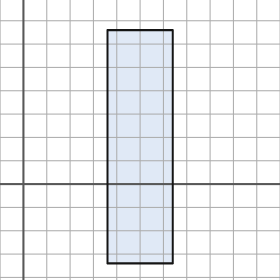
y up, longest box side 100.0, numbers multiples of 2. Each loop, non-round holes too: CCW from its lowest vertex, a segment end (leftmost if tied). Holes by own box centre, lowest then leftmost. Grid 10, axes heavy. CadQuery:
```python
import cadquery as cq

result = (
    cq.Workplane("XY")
    .moveTo(36.0, -34.0)
    .lineTo(64.0, -34.0)
    .lineTo(64.0, 66.0)
    .lineTo(36.0, 66.0)
    .close()
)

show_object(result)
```